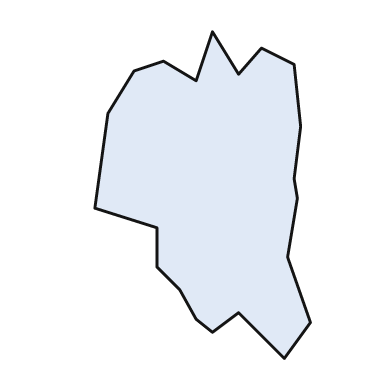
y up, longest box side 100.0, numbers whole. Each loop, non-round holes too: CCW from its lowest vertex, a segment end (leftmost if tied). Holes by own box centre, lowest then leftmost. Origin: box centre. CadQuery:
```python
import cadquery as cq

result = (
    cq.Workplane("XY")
    .moveTo(25.0, -50.0)
    .lineTo(33.0, -39.0)
    .lineTo(26.0, -19.0)
    .lineTo(29.0, -1.0)
    .lineTo(28.0, 5.0)
    .lineTo(30.0, 21.0)
    .lineTo(28.0, 40.0)
    .lineTo(18.0, 45.0)
    .lineTo(11.0, 37.0)
    .lineTo(3.0, 50.0)
    .lineTo(-2.0, 35.0)
    .lineTo(-12.0, 41.0)
    .lineTo(-21.0, 38.0)
    .lineTo(-29.0, 25.0)
    .lineTo(-33.0, -4.0)
    .lineTo(-14.0, -10.0)
    .lineTo(-14.0, -22.0)
    .lineTo(-7.0, -29.0)
    .lineTo(-2.0, -38.0)
    .lineTo(3.0, -42.0)
    .lineTo(11.0, -36.0)
    .close()
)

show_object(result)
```